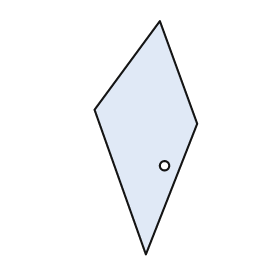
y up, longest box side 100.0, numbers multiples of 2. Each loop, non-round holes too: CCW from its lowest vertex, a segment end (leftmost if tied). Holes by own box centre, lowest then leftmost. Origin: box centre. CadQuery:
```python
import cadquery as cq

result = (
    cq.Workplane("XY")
    .moveTo(0.0, -50.0)
    .lineTo(22.0, 6.0)
    .lineTo(6.0, 50.0)
    .lineTo(-22.0, 12.0)
    .close()
    .moveTo(8.0, -12.0)
    .circle(2.0)
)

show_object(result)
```